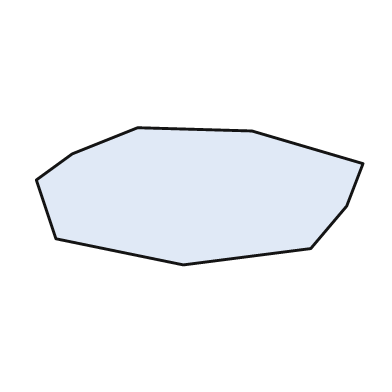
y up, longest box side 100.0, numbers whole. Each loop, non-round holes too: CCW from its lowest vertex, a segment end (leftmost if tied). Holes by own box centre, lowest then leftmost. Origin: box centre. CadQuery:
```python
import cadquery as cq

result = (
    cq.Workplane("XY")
    .moveTo(-5.0, -21.0)
    .lineTo(34.0, -16.0)
    .lineTo(45.0, -3.0)
    .lineTo(50.0, 10.0)
    .lineTo(16.0, 20.0)
    .lineTo(-19.0, 21.0)
    .lineTo(-39.0, 13.0)
    .lineTo(-50.0, 5.0)
    .lineTo(-44.0, -13.0)
    .close()
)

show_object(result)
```